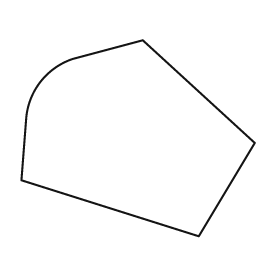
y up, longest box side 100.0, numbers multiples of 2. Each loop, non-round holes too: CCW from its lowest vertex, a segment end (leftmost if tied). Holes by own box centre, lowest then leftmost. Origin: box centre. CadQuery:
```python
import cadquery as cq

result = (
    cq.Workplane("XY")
    .moveTo(26.0, -42.0)
    .lineTo(50.0, -2.0)
    .lineTo(2.0, 42.0)
    .lineTo(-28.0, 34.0)
    .threePointArc((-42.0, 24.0), (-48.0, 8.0))
    .lineTo(-50.0, -18.0)
    .close()
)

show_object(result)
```